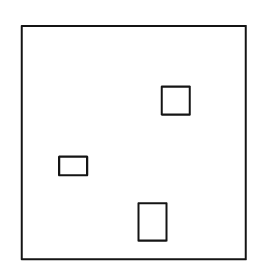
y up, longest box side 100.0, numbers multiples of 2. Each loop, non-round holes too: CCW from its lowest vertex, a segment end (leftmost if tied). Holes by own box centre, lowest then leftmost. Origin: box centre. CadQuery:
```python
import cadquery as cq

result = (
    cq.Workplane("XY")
    .moveTo(-48.0, -50.0)
    .lineTo(48.0, -50.0)
    .lineTo(48.0, 50.0)
    .lineTo(-48.0, 50.0)
    .close()
    .moveTo(2.0, -42.0)
    .lineTo(14.0, -42.0)
    .lineTo(14.0, -26.0)
    .lineTo(2.0, -26.0)
    .close()
    .moveTo(-32.0, -14.0)
    .lineTo(-20.0, -14.0)
    .lineTo(-20.0, -6.0)
    .lineTo(-32.0, -6.0)
    .close()
    .moveTo(12.0, 12.0)
    .lineTo(24.0, 12.0)
    .lineTo(24.0, 24.0)
    .lineTo(12.0, 24.0)
    .close()
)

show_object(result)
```